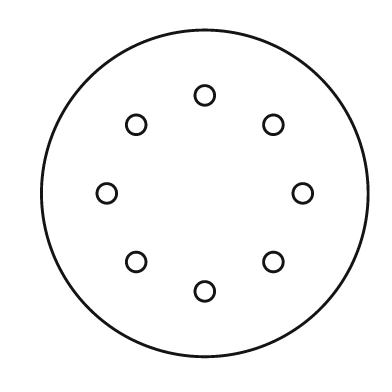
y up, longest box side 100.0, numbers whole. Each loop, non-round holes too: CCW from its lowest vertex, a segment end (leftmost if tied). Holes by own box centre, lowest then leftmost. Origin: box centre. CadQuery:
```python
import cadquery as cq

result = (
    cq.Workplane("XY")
    .moveTo(0.0, 0.0)
    .circle(50.0)
    .moveTo(0.0, -30.0)
    .circle(3.0)
    .moveTo(-21.0, -21.0)
    .circle(3.0)
    .moveTo(21.0, -21.0)
    .circle(3.0)
    .moveTo(-30.0, 0.0)
    .circle(3.0)
    .moveTo(30.0, 0.0)
    .circle(3.0)
    .moveTo(-21.0, 21.0)
    .circle(3.0)
    .moveTo(21.0, 21.0)
    .circle(3.0)
    .moveTo(0.0, 30.0)
    .circle(3.0)
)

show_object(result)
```